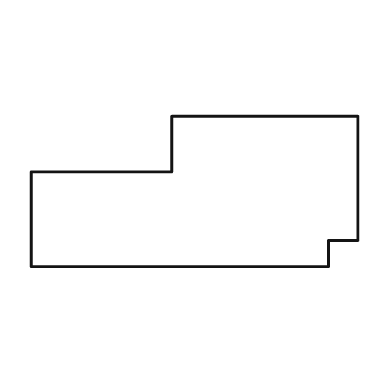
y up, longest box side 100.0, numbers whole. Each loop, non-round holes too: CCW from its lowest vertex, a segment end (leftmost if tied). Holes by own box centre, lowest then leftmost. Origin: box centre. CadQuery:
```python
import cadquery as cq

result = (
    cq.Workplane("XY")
    .moveTo(-50.0, -23.0)
    .lineTo(41.0, -23.0)
    .lineTo(41.0, -15.0)
    .lineTo(50.0, -15.0)
    .lineTo(50.0, 23.0)
    .lineTo(-7.0, 23.0)
    .lineTo(-7.0, 6.0)
    .lineTo(-50.0, 6.0)
    .close()
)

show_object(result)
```